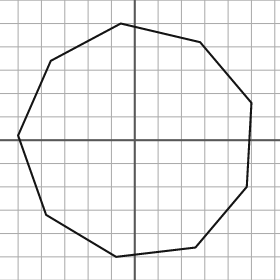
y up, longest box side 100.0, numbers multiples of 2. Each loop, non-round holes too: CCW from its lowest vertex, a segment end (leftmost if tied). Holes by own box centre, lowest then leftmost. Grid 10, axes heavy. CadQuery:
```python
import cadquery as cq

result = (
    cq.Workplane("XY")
    .moveTo(-8.0, -50.0)
    .lineTo(26.0, -46.0)
    .lineTo(48.0, -20.0)
    .lineTo(50.0, 16.0)
    .lineTo(28.0, 42.0)
    .lineTo(-6.0, 50.0)
    .lineTo(-36.0, 34.0)
    .lineTo(-50.0, 2.0)
    .lineTo(-38.0, -32.0)
    .close()
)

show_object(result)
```